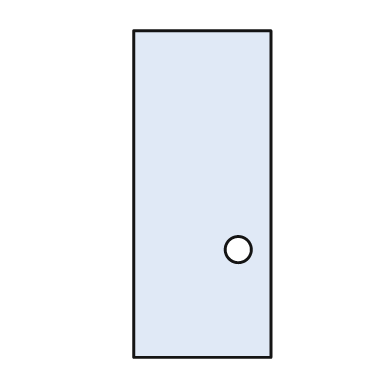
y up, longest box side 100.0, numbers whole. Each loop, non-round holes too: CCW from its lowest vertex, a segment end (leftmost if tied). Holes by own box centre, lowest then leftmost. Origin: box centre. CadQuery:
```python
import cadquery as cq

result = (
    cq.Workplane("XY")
    .moveTo(-21.0, -50.0)
    .lineTo(21.0, -50.0)
    .lineTo(21.0, 50.0)
    .lineTo(-21.0, 50.0)
    .close()
    .moveTo(11.0, -17.0)
    .circle(4.0)
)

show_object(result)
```